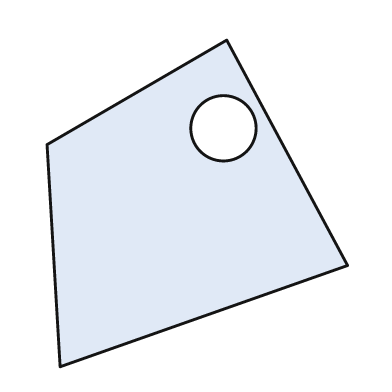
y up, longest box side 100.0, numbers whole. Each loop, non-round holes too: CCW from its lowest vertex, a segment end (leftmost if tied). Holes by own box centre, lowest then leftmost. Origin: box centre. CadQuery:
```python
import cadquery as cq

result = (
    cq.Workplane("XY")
    .moveTo(-42.0, -50.0)
    .lineTo(46.0, -19.0)
    .lineTo(9.0, 50.0)
    .lineTo(-46.0, 18.0)
    .close()
    .moveTo(8.0, 23.0)
    .circle(10.0)
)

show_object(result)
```